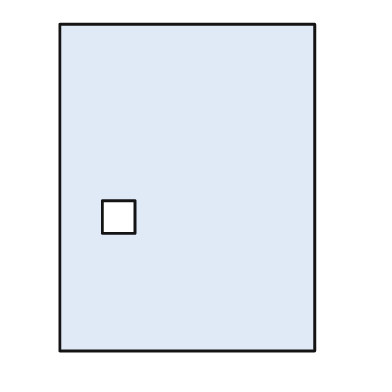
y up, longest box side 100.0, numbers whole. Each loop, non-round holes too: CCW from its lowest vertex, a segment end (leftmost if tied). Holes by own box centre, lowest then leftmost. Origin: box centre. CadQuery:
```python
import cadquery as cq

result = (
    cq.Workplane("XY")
    .moveTo(-39.0, -50.0)
    .lineTo(39.0, -50.0)
    .lineTo(39.0, 50.0)
    .lineTo(-39.0, 50.0)
    .close()
    .moveTo(-26.0, -14.0)
    .lineTo(-16.0, -14.0)
    .lineTo(-16.0, -4.0)
    .lineTo(-26.0, -4.0)
    .close()
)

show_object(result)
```